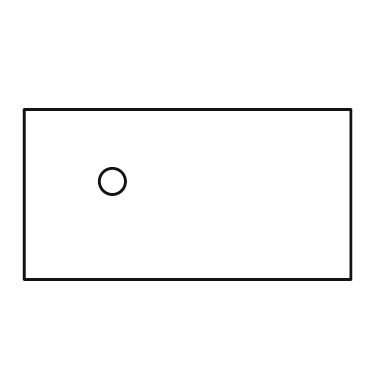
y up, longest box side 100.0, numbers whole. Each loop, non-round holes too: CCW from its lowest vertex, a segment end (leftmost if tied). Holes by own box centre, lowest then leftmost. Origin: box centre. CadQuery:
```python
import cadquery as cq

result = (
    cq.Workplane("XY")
    .moveTo(-50.0, -26.0)
    .lineTo(50.0, -26.0)
    .lineTo(50.0, 26.0)
    .lineTo(-50.0, 26.0)
    .close()
    .moveTo(-23.0, 4.0)
    .circle(4.0)
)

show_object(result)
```